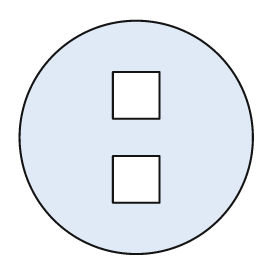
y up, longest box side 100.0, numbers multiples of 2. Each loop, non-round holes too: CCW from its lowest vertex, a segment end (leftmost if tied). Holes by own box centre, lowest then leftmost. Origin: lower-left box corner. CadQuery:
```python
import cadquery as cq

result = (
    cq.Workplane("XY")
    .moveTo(50.0, 50.0)
    .circle(50.0)
    .moveTo(40.0, 22.0)
    .lineTo(60.0, 22.0)
    .lineTo(60.0, 42.0)
    .lineTo(40.0, 42.0)
    .close()
    .moveTo(40.0, 58.0)
    .lineTo(60.0, 58.0)
    .lineTo(60.0, 78.0)
    .lineTo(40.0, 78.0)
    .close()
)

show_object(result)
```